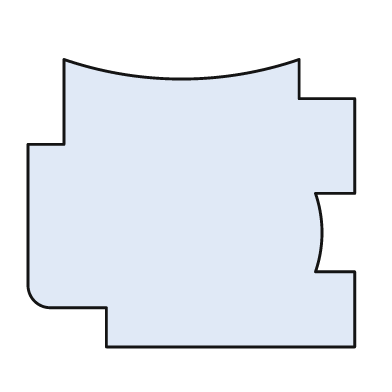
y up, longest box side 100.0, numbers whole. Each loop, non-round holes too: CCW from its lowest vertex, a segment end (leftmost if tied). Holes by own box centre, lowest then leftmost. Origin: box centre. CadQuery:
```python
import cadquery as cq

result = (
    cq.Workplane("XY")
    .moveTo(-26.0, -44.0)
    .lineTo(50.0, -44.0)
    .lineTo(50.0, -21.0)
    .lineTo(38.0, -21.0)
    .threePointArc((40.0, -9.0), (38.0, 3.0))
    .lineTo(50.0, 3.0)
    .lineTo(50.0, 32.0)
    .lineTo(33.0, 32.0)
    .lineTo(33.0, 44.0)
    .threePointArc((-3.0, 38.0), (-39.0, 44.0))
    .lineTo(-39.0, 18.0)
    .lineTo(-50.0, 18.0)
    .lineTo(-50.0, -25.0)
    .threePointArc((-48.0, -30.0), (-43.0, -32.0))
    .lineTo(-26.0, -32.0)
    .close()
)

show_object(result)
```